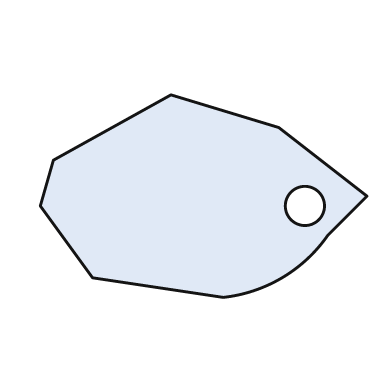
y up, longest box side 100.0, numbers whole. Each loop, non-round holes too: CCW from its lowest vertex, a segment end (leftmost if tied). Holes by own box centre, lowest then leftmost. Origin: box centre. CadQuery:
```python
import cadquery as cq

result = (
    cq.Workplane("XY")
    .moveTo(6.0, -31.0)
    .threePointArc((24.0, -25.0), (38.0, -12.0))
    .lineTo(50.0, 0.0)
    .lineTo(23.0, 21.0)
    .lineTo(-10.0, 31.0)
    .lineTo(-46.0, 11.0)
    .lineTo(-50.0, -3.0)
    .lineTo(-34.0, -25.0)
    .close()
    .moveTo(31.0, -3.0)
    .circle(6.0)
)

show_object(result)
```